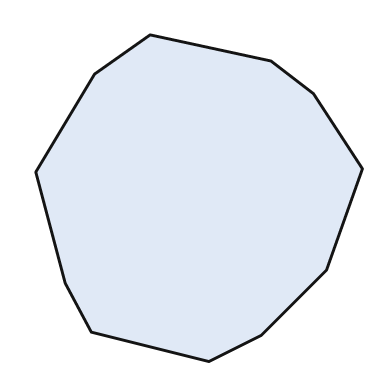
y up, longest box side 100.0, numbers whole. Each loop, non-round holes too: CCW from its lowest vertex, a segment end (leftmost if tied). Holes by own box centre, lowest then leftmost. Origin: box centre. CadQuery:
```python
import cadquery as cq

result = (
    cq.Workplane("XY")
    .moveTo(3.0, -50.0)
    .lineTo(19.0, -42.0)
    .lineTo(39.0, -22.0)
    .lineTo(50.0, 9.0)
    .lineTo(35.0, 32.0)
    .lineTo(22.0, 42.0)
    .lineTo(-15.0, 50.0)
    .lineTo(-32.0, 38.0)
    .lineTo(-50.0, 8.0)
    .lineTo(-41.0, -26.0)
    .lineTo(-33.0, -41.0)
    .close()
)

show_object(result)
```